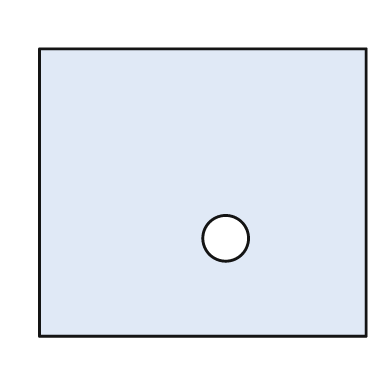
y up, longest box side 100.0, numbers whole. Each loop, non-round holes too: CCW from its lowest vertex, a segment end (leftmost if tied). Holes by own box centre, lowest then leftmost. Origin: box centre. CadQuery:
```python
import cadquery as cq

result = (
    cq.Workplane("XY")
    .moveTo(-50.0, -44.0)
    .lineTo(50.0, -44.0)
    .lineTo(50.0, 44.0)
    .lineTo(-50.0, 44.0)
    .close()
    .moveTo(7.0, -14.0)
    .circle(7.0)
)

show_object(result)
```